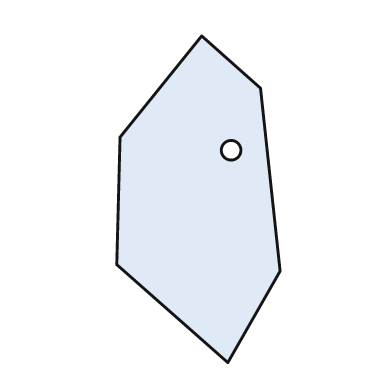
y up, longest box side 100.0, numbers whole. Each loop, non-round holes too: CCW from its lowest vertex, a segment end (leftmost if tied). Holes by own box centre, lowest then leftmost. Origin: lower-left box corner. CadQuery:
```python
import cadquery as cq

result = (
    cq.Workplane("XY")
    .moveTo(34.0, 0.0)
    .lineTo(50.0, 28.0)
    .lineTo(44.0, 84.0)
    .lineTo(26.0, 100.0)
    .lineTo(1.0, 69.0)
    .lineTo(0.0, 30.0)
    .close()
    .moveTo(35.0, 65.0)
    .circle(3.0)
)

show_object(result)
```